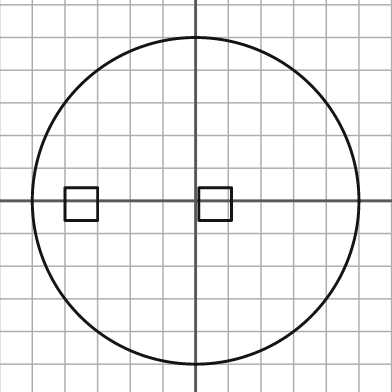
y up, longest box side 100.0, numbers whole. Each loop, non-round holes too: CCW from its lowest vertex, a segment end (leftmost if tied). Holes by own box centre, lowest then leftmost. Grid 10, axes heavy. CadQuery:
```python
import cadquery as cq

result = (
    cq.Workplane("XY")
    .moveTo(0.0, 0.0)
    .circle(50.0)
    .moveTo(-40.0, -6.0)
    .lineTo(-30.0, -6.0)
    .lineTo(-30.0, 4.0)
    .lineTo(-40.0, 4.0)
    .close()
    .moveTo(1.0, -6.0)
    .lineTo(11.0, -6.0)
    .lineTo(11.0, 4.0)
    .lineTo(1.0, 4.0)
    .close()
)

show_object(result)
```